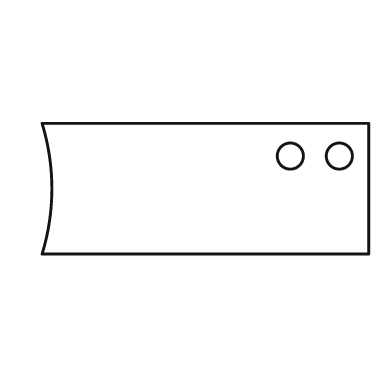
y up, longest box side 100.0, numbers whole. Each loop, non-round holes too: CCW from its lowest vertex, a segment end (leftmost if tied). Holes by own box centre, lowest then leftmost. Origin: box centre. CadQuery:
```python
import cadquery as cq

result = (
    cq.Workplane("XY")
    .moveTo(-50.0, -20.0)
    .lineTo(50.0, -20.0)
    .lineTo(50.0, 20.0)
    .lineTo(-50.0, 20.0)
    .threePointArc((-47.0, 0.0), (-50.0, -20.0))
    .close()
    .moveTo(26.0, 10.0)
    .circle(4.0)
    .moveTo(41.0, 10.0)
    .circle(4.0)
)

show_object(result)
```